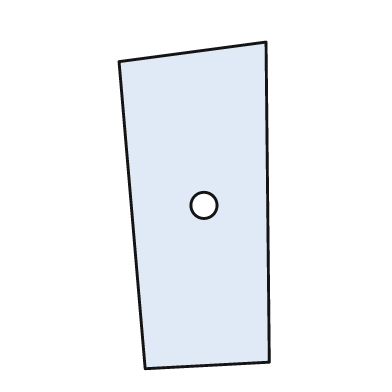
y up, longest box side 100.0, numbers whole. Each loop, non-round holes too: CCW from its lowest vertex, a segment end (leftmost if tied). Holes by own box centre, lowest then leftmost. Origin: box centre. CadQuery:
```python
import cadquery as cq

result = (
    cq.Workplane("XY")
    .moveTo(-15.0, -50.0)
    .lineTo(23.0, -48.0)
    .lineTo(22.0, 50.0)
    .lineTo(-23.0, 44.0)
    .close()
    .moveTo(3.0, 0.0)
    .circle(4.0)
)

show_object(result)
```